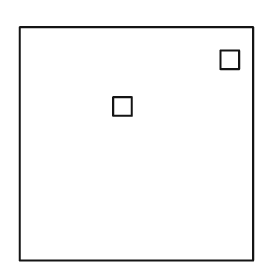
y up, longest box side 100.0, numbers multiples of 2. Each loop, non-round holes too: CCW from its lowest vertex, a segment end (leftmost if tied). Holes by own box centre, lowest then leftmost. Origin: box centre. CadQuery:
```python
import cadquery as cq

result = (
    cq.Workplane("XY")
    .moveTo(-50.0, -50.0)
    .lineTo(50.0, -50.0)
    .lineTo(50.0, 50.0)
    .lineTo(-50.0, 50.0)
    .close()
    .moveTo(-10.0, 12.0)
    .lineTo(-2.0, 12.0)
    .lineTo(-2.0, 20.0)
    .lineTo(-10.0, 20.0)
    .close()
    .moveTo(36.0, 32.0)
    .lineTo(44.0, 32.0)
    .lineTo(44.0, 40.0)
    .lineTo(36.0, 40.0)
    .close()
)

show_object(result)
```